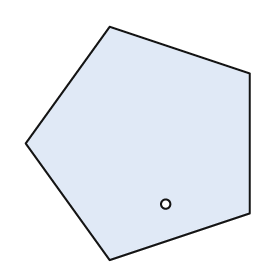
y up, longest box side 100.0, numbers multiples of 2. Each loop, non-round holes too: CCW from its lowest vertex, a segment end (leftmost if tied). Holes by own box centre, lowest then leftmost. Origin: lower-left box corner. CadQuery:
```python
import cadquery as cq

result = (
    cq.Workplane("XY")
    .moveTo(36.0, 0.0)
    .lineTo(96.0, 20.0)
    .lineTo(96.0, 80.0)
    .lineTo(36.0, 100.0)
    .lineTo(0.0, 50.0)
    .close()
    .moveTo(60.0, 24.0)
    .circle(2.0)
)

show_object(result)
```